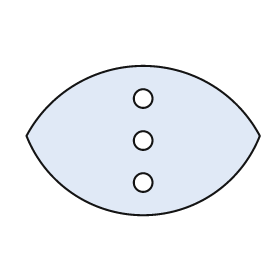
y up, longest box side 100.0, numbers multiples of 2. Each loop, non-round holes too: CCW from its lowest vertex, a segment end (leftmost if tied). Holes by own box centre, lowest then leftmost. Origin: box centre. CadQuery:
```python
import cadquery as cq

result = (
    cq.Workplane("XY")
    .moveTo(-50.0, 2.0)
    .threePointArc((0.0, -32.0), (50.0, 2.0))
    .threePointArc((0.0, 32.0), (-50.0, 2.0))
    .close()
    .moveTo(0.0, -18.0)
    .circle(4.0)
    .moveTo(0.0, 0.0)
    .circle(4.0)
    .moveTo(0.0, 18.0)
    .circle(4.0)
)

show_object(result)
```